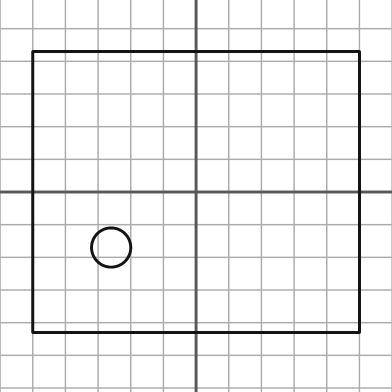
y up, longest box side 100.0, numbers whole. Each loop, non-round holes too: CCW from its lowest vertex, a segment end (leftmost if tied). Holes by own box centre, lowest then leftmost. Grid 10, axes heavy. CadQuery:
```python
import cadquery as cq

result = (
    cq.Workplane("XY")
    .moveTo(-50.0, -43.0)
    .lineTo(50.0, -43.0)
    .lineTo(50.0, 43.0)
    .lineTo(-50.0, 43.0)
    .close()
    .moveTo(-26.0, -17.0)
    .circle(6.0)
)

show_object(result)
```